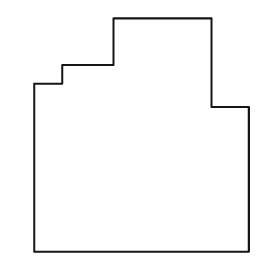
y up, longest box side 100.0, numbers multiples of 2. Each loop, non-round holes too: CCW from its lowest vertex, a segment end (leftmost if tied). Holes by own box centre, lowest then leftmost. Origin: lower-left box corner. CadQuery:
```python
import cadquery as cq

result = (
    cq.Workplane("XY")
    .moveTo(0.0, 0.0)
    .lineTo(92.0, 0.0)
    .lineTo(92.0, 62.0)
    .lineTo(76.0, 62.0)
    .lineTo(76.0, 100.0)
    .lineTo(34.0, 100.0)
    .lineTo(34.0, 80.0)
    .lineTo(12.0, 80.0)
    .lineTo(12.0, 72.0)
    .lineTo(0.0, 72.0)
    .close()
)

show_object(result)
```